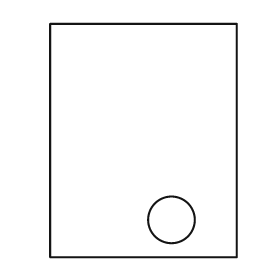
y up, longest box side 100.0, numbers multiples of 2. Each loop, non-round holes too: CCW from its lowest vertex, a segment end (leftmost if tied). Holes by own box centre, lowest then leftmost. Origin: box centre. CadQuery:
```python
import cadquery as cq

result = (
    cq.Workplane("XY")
    .moveTo(-40.0, -50.0)
    .lineTo(40.0, -50.0)
    .lineTo(40.0, 50.0)
    .lineTo(-40.0, 50.0)
    .close()
    .moveTo(12.0, -34.0)
    .circle(10.0)
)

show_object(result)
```